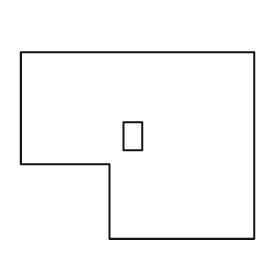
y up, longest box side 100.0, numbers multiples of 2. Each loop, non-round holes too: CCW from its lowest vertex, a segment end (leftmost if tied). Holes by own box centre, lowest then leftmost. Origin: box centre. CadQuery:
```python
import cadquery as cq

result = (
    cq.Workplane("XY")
    .moveTo(-12.0, -40.0)
    .lineTo(50.0, -40.0)
    .lineTo(50.0, 40.0)
    .lineTo(-50.0, 40.0)
    .lineTo(-50.0, -8.0)
    .lineTo(-12.0, -8.0)
    .close()
    .moveTo(-6.0, -2.0)
    .lineTo(2.0, -2.0)
    .lineTo(2.0, 10.0)
    .lineTo(-6.0, 10.0)
    .close()
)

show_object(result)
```